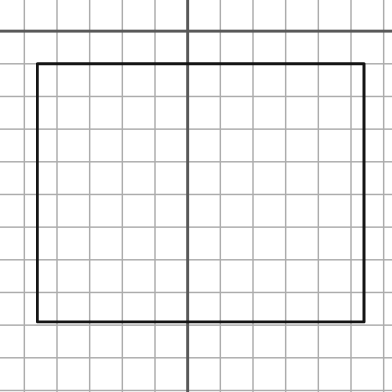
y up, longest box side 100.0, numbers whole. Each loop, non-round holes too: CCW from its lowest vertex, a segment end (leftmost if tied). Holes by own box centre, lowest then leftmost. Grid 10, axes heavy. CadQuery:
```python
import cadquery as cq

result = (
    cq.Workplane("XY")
    .moveTo(-46.0, -89.0)
    .lineTo(54.0, -89.0)
    .lineTo(54.0, -10.0)
    .lineTo(-46.0, -10.0)
    .close()
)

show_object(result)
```